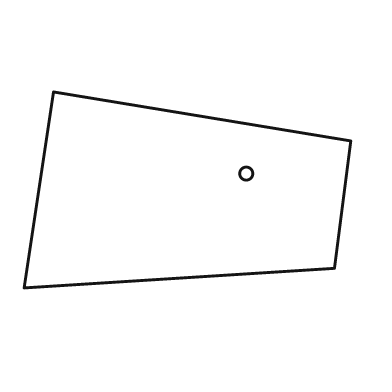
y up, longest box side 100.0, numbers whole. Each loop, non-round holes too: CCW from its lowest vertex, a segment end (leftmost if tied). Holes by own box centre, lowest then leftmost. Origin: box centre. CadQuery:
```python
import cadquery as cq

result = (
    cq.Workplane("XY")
    .moveTo(-50.0, -30.0)
    .lineTo(45.0, -24.0)
    .lineTo(50.0, 15.0)
    .lineTo(-41.0, 30.0)
    .close()
    .moveTo(18.0, 5.0)
    .circle(2.0)
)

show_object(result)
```